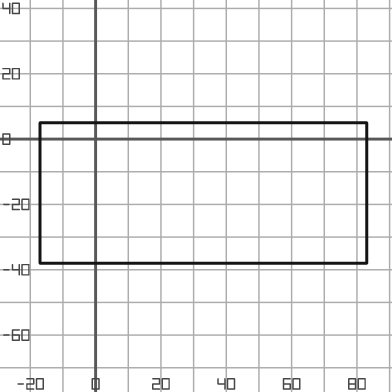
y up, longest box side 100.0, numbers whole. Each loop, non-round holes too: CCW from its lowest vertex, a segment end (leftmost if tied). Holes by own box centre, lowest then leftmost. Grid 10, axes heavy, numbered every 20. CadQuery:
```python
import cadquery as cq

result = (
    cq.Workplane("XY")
    .moveTo(-17.0, -38.0)
    .lineTo(83.0, -38.0)
    .lineTo(83.0, 5.0)
    .lineTo(-17.0, 5.0)
    .close()
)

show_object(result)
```